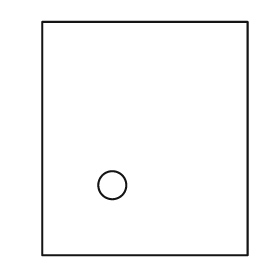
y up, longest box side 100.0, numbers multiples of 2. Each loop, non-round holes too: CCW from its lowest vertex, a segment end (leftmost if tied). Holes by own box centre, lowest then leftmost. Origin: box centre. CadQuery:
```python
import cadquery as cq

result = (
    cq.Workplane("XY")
    .moveTo(-44.0, -50.0)
    .lineTo(44.0, -50.0)
    .lineTo(44.0, 50.0)
    .lineTo(-44.0, 50.0)
    .close()
    .moveTo(-14.0, -20.0)
    .circle(6.0)
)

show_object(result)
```